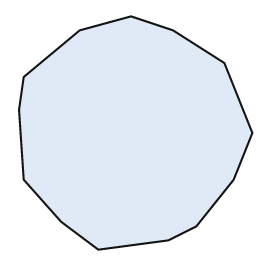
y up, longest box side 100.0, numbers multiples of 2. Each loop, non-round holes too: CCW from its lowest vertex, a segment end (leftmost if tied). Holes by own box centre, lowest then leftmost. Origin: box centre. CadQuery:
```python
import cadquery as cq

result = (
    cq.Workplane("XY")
    .moveTo(-16.0, -50.0)
    .lineTo(14.0, -46.0)
    .lineTo(26.0, -40.0)
    .lineTo(42.0, -20.0)
    .lineTo(50.0, 0.0)
    .lineTo(38.0, 30.0)
    .lineTo(16.0, 44.0)
    .lineTo(-2.0, 50.0)
    .lineTo(-24.0, 44.0)
    .lineTo(-48.0, 24.0)
    .lineTo(-50.0, 10.0)
    .lineTo(-48.0, -20.0)
    .lineTo(-32.0, -38.0)
    .close()
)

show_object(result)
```